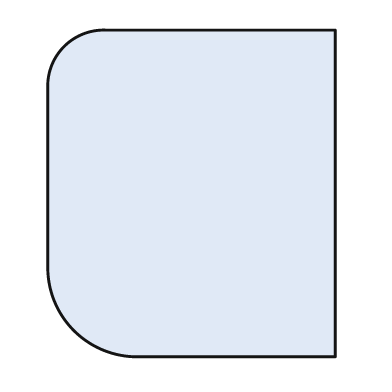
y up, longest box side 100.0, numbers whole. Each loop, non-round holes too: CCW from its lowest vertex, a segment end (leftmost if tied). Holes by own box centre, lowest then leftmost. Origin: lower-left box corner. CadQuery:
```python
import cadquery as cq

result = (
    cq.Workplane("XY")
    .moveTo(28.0, 0.0)
    .lineTo(88.0, 0.0)
    .lineTo(88.0, 100.0)
    .lineTo(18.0, 100.0)
    .threePointArc((5.0, 95.0), (0.0, 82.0))
    .lineTo(0.0, 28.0)
    .threePointArc((8.0, 8.0), (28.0, 0.0))
    .close()
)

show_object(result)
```